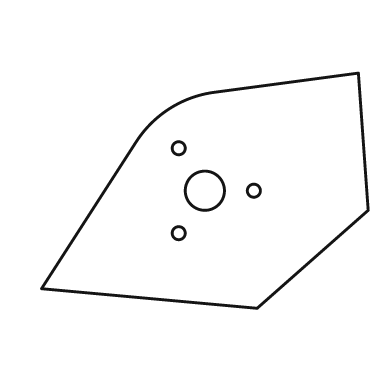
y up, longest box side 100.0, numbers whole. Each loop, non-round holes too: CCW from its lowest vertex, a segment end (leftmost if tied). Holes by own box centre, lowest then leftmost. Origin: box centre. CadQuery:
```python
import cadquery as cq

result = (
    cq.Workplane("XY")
    .moveTo(16.0, -36.0)
    .lineTo(50.0, -6.0)
    .lineTo(47.0, 36.0)
    .lineTo(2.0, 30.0)
    .threePointArc((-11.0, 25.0), (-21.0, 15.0))
    .lineTo(-50.0, -30.0)
    .close()
    .moveTo(-8.0, -13.0)
    .circle(2.0)
    .moveTo(0.0, 0.0)
    .circle(6.0)
    .moveTo(15.0, 0.0)
    .circle(2.0)
    .moveTo(-8.0, 13.0)
    .circle(2.0)
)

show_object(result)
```